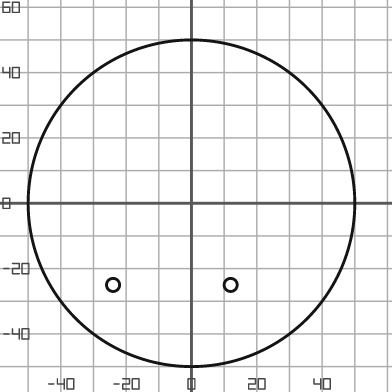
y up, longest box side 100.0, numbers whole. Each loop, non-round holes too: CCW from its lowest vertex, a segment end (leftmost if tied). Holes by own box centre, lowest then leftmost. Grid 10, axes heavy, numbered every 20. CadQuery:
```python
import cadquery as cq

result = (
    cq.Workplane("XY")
    .moveTo(0.0, 0.0)
    .circle(50.0)
    .moveTo(-24.0, -25.0)
    .circle(2.0)
    .moveTo(12.0, -25.0)
    .circle(2.0)
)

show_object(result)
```